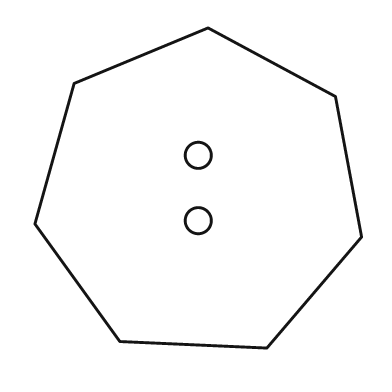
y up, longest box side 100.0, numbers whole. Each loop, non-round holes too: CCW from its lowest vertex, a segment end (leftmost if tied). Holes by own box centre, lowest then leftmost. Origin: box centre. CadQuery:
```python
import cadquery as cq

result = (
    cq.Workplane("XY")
    .moveTo(21.0, -49.0)
    .lineTo(50.0, -15.0)
    .lineTo(42.0, 28.0)
    .lineTo(3.0, 49.0)
    .lineTo(-38.0, 32.0)
    .lineTo(-50.0, -11.0)
    .lineTo(-24.0, -47.0)
    .close()
    .moveTo(0.0, -10.0)
    .circle(4.0)
    .moveTo(0.0, 10.0)
    .circle(4.0)
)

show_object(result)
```